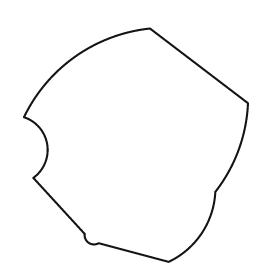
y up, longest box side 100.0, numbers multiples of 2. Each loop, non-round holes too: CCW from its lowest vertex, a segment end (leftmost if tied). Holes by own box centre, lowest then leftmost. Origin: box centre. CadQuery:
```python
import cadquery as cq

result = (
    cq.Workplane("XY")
    .moveTo(14.0, -50.0)
    .threePointArc((28.0, -38.0), (34.0, -20.0))
    .threePointArc((44.0, -2.0), (48.0, 18.0))
    .lineTo(6.0, 50.0)
    .threePointArc((-26.0, 38.0), (-48.0, 12.0))
    .threePointArc((-38.0, 0.0), (-44.0, -14.0))
    .lineTo(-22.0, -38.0)
    .threePointArc((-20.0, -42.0), (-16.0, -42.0))
    .close()
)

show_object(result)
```